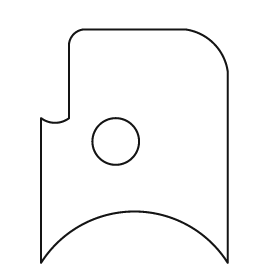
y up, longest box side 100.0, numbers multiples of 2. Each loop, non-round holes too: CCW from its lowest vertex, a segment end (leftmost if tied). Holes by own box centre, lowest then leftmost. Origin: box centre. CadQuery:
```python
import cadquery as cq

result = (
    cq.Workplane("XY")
    .moveTo(-40.0, -50.0)
    .threePointArc((0.0, -28.0), (40.0, -50.0))
    .lineTo(40.0, 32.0)
    .threePointArc((34.0, 44.0), (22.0, 50.0))
    .lineTo(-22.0, 50.0)
    .threePointArc((-26.0, 48.0), (-28.0, 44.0))
    .lineTo(-28.0, 12.0)
    .threePointArc((-34.0, 10.0), (-40.0, 12.0))
    .close()
    .moveTo(-8.0, 2.0)
    .circle(10.0)
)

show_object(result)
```